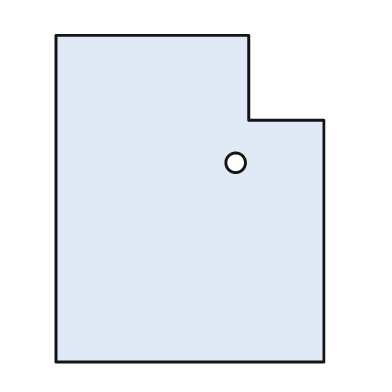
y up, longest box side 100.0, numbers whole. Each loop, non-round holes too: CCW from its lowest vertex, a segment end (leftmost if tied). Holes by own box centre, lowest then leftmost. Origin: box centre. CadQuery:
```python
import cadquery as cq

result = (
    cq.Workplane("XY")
    .moveTo(-41.0, -50.0)
    .lineTo(41.0, -50.0)
    .lineTo(41.0, 24.0)
    .lineTo(18.0, 24.0)
    .lineTo(18.0, 50.0)
    .lineTo(-41.0, 50.0)
    .close()
    .moveTo(14.0, 11.0)
    .circle(3.0)
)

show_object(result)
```